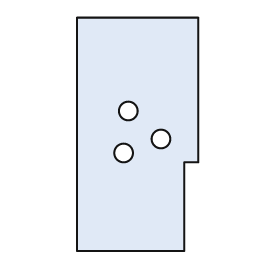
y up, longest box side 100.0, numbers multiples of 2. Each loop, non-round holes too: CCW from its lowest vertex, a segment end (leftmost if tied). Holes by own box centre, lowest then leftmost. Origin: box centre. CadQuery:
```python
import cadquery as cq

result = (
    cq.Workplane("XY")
    .moveTo(-26.0, -50.0)
    .lineTo(20.0, -50.0)
    .lineTo(20.0, -12.0)
    .lineTo(26.0, -12.0)
    .lineTo(26.0, 50.0)
    .lineTo(-26.0, 50.0)
    .close()
    .moveTo(-6.0, -8.0)
    .circle(4.0)
    .moveTo(10.0, -2.0)
    .circle(4.0)
    .moveTo(-4.0, 10.0)
    .circle(4.0)
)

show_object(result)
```